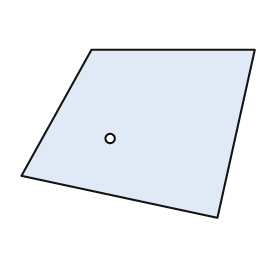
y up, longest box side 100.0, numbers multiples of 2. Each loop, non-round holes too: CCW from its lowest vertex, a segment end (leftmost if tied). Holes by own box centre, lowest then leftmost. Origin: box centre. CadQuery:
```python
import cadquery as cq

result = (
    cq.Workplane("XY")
    .moveTo(34.0, -36.0)
    .lineTo(50.0, 36.0)
    .lineTo(-20.0, 36.0)
    .lineTo(-50.0, -18.0)
    .close()
    .moveTo(-12.0, -2.0)
    .circle(2.0)
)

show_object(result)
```